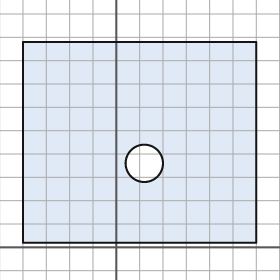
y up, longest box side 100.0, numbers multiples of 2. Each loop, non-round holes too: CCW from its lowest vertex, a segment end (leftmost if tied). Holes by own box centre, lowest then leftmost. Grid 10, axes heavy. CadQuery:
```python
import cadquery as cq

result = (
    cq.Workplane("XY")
    .moveTo(-40.0, 2.0)
    .lineTo(60.0, 2.0)
    .lineTo(60.0, 88.0)
    .lineTo(-40.0, 88.0)
    .close()
    .moveTo(12.0, 36.0)
    .circle(8.0)
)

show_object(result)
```